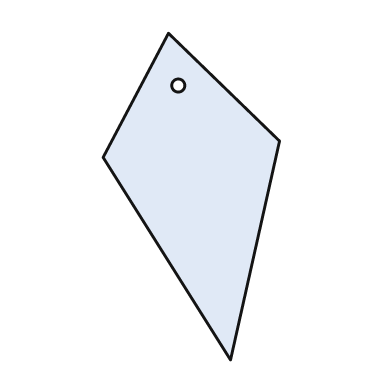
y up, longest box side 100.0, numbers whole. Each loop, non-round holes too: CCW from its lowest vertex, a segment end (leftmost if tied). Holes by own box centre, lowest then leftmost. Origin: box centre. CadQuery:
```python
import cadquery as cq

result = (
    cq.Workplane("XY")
    .moveTo(12.0, -50.0)
    .lineTo(27.0, 17.0)
    .lineTo(-7.0, 50.0)
    .lineTo(-27.0, 12.0)
    .close()
    .moveTo(-4.0, 34.0)
    .circle(2.0)
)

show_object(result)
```